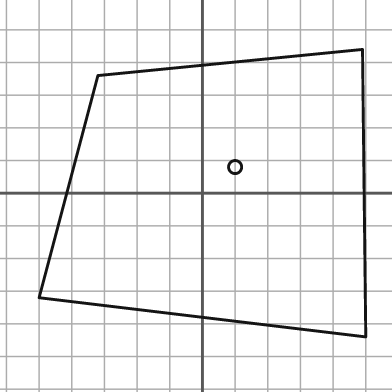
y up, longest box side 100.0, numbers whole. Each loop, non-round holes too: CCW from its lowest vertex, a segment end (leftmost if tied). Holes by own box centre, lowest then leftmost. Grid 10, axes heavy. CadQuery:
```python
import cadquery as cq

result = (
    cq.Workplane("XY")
    .moveTo(50.0, -44.0)
    .lineTo(49.0, 44.0)
    .lineTo(-32.0, 36.0)
    .lineTo(-50.0, -32.0)
    .close()
    .moveTo(10.0, 8.0)
    .circle(2.0)
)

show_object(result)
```